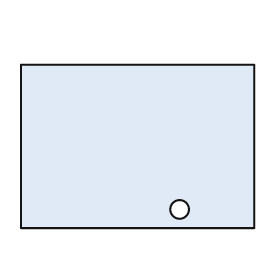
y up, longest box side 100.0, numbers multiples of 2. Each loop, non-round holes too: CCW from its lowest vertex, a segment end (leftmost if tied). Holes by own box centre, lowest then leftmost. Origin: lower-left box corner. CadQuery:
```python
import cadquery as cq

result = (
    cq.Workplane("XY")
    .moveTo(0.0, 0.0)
    .lineTo(100.0, 0.0)
    .lineTo(100.0, 70.0)
    .lineTo(0.0, 70.0)
    .close()
    .moveTo(68.0, 8.0)
    .circle(4.0)
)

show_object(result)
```